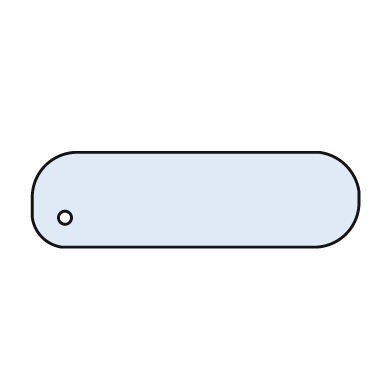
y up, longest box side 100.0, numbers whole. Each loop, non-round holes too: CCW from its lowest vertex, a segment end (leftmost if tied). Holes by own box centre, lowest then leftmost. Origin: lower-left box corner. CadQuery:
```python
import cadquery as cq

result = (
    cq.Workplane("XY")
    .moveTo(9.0, 0.0)
    .lineTo(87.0, 0.0)
    .threePointArc((96.0, 4.0), (100.0, 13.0))
    .lineTo(100.0, 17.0)
    .threePointArc((96.0, 25.0), (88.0, 29.0))
    .lineTo(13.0, 29.0)
    .threePointArc((4.0, 25.0), (0.0, 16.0))
    .lineTo(0.0, 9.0)
    .threePointArc((3.0, 3.0), (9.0, 0.0))
    .close()
    .moveTo(10.0, 9.0)
    .circle(2.0)
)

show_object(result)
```